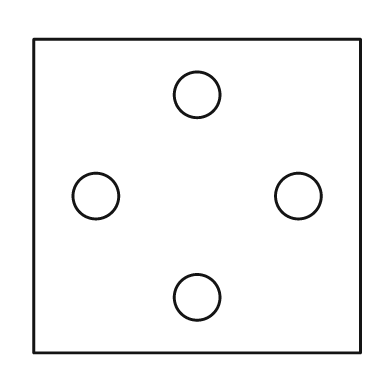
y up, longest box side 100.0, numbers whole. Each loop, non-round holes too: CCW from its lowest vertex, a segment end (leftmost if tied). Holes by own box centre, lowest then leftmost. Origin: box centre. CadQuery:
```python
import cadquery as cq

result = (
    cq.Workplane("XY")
    .moveTo(-50.0, -48.0)
    .lineTo(50.0, -48.0)
    .lineTo(50.0, 48.0)
    .lineTo(-50.0, 48.0)
    .close()
    .moveTo(0.0, -31.0)
    .circle(7.0)
    .moveTo(-31.0, 0.0)
    .circle(7.0)
    .moveTo(31.0, 0.0)
    .circle(7.0)
    .moveTo(0.0, 31.0)
    .circle(7.0)
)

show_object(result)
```